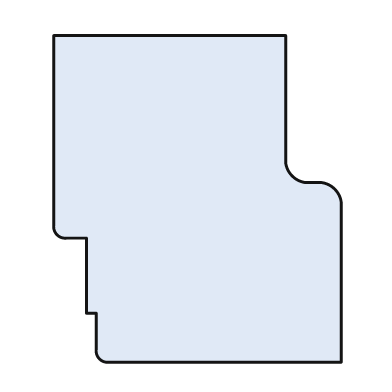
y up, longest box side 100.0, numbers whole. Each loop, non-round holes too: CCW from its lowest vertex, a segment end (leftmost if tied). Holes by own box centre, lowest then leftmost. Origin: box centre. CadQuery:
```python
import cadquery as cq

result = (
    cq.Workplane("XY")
    .moveTo(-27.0, -50.0)
    .lineTo(44.0, -50.0)
    .lineTo(44.0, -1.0)
    .threePointArc((42.0, 3.0), (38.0, 5.0))
    .lineTo(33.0, 5.0)
    .threePointArc((29.0, 7.0), (27.0, 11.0))
    .lineTo(27.0, 50.0)
    .lineTo(-44.0, 50.0)
    .lineTo(-44.0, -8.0)
    .threePointArc((-43.0, -11.0), (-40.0, -12.0))
    .lineTo(-34.0, -12.0)
    .lineTo(-34.0, -35.0)
    .lineTo(-31.0, -35.0)
    .lineTo(-31.0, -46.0)
    .threePointArc((-30.0, -49.0), (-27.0, -50.0))
    .close()
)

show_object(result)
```